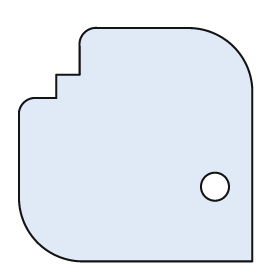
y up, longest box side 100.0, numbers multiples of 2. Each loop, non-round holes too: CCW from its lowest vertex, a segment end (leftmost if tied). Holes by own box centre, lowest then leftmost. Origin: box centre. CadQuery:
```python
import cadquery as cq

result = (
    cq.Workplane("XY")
    .moveTo(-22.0, -50.0)
    .lineTo(50.0, -50.0)
    .lineTo(50.0, 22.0)
    .threePointArc((42.0, 42.0), (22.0, 50.0))
    .lineTo(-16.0, 50.0)
    .threePointArc((-22.0, 48.0), (-24.0, 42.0))
    .lineTo(-24.0, 30.0)
    .lineTo(-34.0, 30.0)
    .lineTo(-34.0, 20.0)
    .lineTo(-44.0, 20.0)
    .threePointArc((-48.0, 18.0), (-50.0, 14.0))
    .lineTo(-50.0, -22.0)
    .threePointArc((-42.0, -42.0), (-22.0, -50.0))
    .close()
    .moveTo(34.0, -18.0)
    .circle(6.0)
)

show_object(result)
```